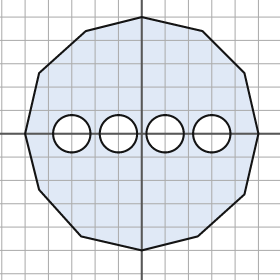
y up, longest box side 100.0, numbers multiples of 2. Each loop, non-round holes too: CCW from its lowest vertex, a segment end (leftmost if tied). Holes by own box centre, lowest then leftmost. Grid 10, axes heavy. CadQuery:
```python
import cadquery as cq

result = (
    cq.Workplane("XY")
    .moveTo(0.0, -50.0)
    .lineTo(24.0, -44.0)
    .lineTo(44.0, -26.0)
    .lineTo(50.0, 0.0)
    .lineTo(44.0, 26.0)
    .lineTo(26.0, 44.0)
    .lineTo(0.0, 50.0)
    .lineTo(-24.0, 44.0)
    .lineTo(-44.0, 26.0)
    .lineTo(-50.0, 0.0)
    .lineTo(-44.0, -24.0)
    .lineTo(-26.0, -44.0)
    .close()
    .moveTo(-30.0, 0.0)
    .circle(8.0)
    .moveTo(-10.0, 0.0)
    .circle(8.0)
    .moveTo(10.0, 0.0)
    .circle(8.0)
    .moveTo(30.0, 0.0)
    .circle(8.0)
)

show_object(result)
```